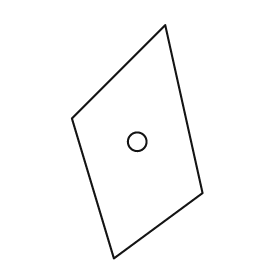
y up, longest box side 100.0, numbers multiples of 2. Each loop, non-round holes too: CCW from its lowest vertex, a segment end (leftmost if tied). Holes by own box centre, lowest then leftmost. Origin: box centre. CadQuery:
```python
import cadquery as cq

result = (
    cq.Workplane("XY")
    .moveTo(-10.0, -50.0)
    .lineTo(28.0, -22.0)
    .lineTo(12.0, 50.0)
    .lineTo(-28.0, 10.0)
    .close()
    .moveTo(0.0, 0.0)
    .circle(4.0)
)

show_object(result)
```